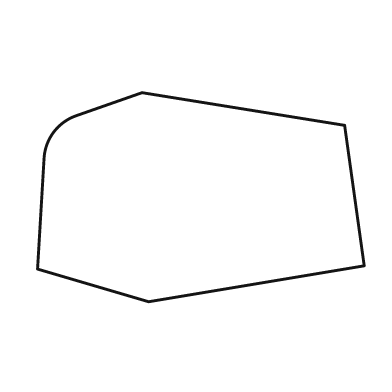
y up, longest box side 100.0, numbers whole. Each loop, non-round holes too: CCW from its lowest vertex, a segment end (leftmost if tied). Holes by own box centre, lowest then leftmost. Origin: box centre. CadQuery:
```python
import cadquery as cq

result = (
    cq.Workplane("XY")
    .moveTo(-16.0, -32.0)
    .lineTo(50.0, -21.0)
    .lineTo(44.0, 22.0)
    .lineTo(-18.0, 32.0)
    .lineTo(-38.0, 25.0)
    .threePointArc((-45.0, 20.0), (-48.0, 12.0))
    .lineTo(-50.0, -22.0)
    .close()
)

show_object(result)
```